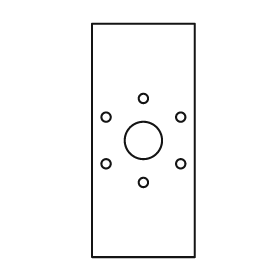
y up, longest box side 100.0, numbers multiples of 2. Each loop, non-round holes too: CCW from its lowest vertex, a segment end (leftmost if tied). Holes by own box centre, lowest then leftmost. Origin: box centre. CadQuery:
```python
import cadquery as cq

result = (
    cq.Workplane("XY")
    .moveTo(-22.0, -50.0)
    .lineTo(22.0, -50.0)
    .lineTo(22.0, 50.0)
    .lineTo(-22.0, 50.0)
    .close()
    .moveTo(0.0, -18.0)
    .circle(2.0)
    .moveTo(-16.0, -10.0)
    .circle(2.0)
    .moveTo(16.0, -10.0)
    .circle(2.0)
    .moveTo(0.0, 0.0)
    .circle(8.0)
    .moveTo(-16.0, 10.0)
    .circle(2.0)
    .moveTo(16.0, 10.0)
    .circle(2.0)
    .moveTo(0.0, 18.0)
    .circle(2.0)
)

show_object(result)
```